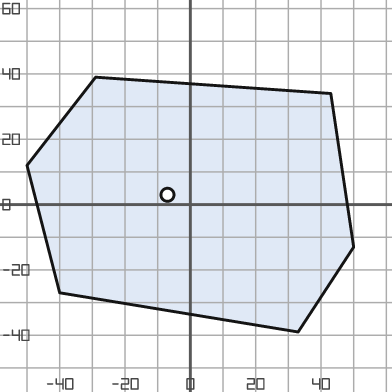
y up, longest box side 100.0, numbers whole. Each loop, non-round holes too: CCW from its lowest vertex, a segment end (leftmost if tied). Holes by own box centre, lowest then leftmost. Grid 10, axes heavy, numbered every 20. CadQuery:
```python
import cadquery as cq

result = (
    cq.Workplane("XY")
    .moveTo(33.0, -39.0)
    .lineTo(50.0, -13.0)
    .lineTo(43.0, 34.0)
    .lineTo(-29.0, 39.0)
    .lineTo(-50.0, 12.0)
    .lineTo(-40.0, -27.0)
    .close()
    .moveTo(-7.0, 3.0)
    .circle(2.0)
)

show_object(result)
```